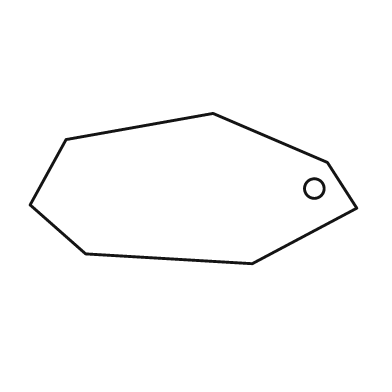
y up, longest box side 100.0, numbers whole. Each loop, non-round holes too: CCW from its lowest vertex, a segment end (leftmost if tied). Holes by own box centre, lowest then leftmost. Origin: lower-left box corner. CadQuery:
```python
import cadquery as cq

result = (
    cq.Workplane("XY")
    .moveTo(68.0, 0.0)
    .lineTo(100.0, 17.0)
    .lineTo(91.0, 31.0)
    .lineTo(56.0, 46.0)
    .lineTo(11.0, 38.0)
    .lineTo(0.0, 18.0)
    .lineTo(17.0, 3.0)
    .close()
    .moveTo(87.0, 23.0)
    .circle(3.0)
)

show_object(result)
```